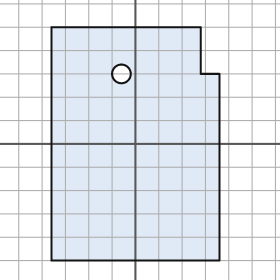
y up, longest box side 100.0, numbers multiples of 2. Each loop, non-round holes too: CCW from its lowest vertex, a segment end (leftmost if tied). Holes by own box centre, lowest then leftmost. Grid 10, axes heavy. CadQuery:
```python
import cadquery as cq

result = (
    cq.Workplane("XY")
    .moveTo(-36.0, -50.0)
    .lineTo(36.0, -50.0)
    .lineTo(36.0, 30.0)
    .lineTo(28.0, 30.0)
    .lineTo(28.0, 50.0)
    .lineTo(-36.0, 50.0)
    .close()
    .moveTo(-6.0, 30.0)
    .circle(4.0)
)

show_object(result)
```